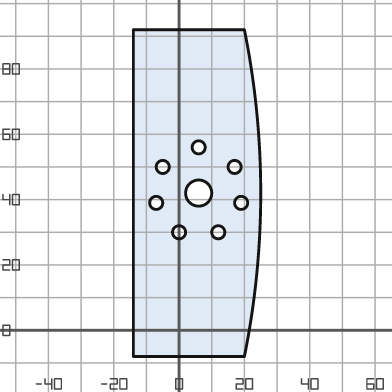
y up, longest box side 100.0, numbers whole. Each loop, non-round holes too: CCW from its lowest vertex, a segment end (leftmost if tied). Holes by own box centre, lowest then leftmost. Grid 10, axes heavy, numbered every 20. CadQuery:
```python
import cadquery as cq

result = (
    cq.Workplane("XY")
    .moveTo(-14.0, -8.0)
    .lineTo(20.0, -8.0)
    .threePointArc((25.0, 42.0), (20.0, 92.0))
    .lineTo(-14.0, 92.0)
    .close()
    .moveTo(0.0, 30.0)
    .circle(2.0)
    .moveTo(12.0, 30.0)
    .circle(2.0)
    .moveTo(-7.0, 39.0)
    .circle(2.0)
    .moveTo(19.0, 39.0)
    .circle(2.0)
    .moveTo(6.0, 42.0)
    .circle(4.0)
    .moveTo(-5.0, 50.0)
    .circle(2.0)
    .moveTo(17.0, 50.0)
    .circle(2.0)
    .moveTo(6.0, 56.0)
    .circle(2.0)
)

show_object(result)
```